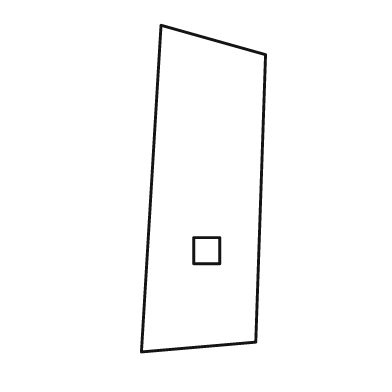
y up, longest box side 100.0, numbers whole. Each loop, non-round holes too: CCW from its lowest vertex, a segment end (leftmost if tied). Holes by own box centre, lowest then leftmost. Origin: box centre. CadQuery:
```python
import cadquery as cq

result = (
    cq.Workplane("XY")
    .moveTo(-19.0, -50.0)
    .lineTo(16.0, -47.0)
    .lineTo(19.0, 41.0)
    .lineTo(-13.0, 50.0)
    .close()
    .moveTo(-3.0, -23.0)
    .lineTo(5.0, -23.0)
    .lineTo(5.0, -15.0)
    .lineTo(-3.0, -15.0)
    .close()
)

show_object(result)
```